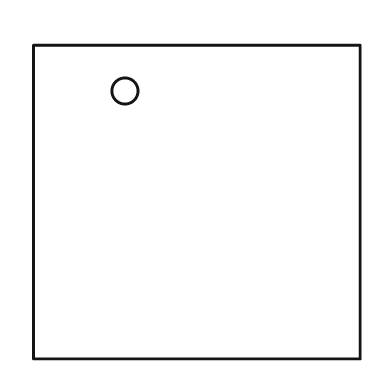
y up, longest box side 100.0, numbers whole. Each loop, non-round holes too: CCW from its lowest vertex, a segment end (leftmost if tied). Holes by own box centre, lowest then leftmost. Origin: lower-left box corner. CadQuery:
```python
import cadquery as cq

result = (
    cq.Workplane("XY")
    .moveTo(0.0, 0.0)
    .lineTo(100.0, 0.0)
    .lineTo(100.0, 96.0)
    .lineTo(0.0, 96.0)
    .close()
    .moveTo(28.0, 82.0)
    .circle(4.0)
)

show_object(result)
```